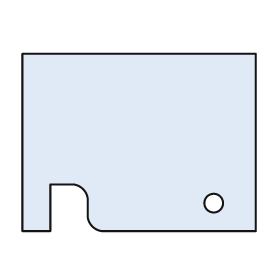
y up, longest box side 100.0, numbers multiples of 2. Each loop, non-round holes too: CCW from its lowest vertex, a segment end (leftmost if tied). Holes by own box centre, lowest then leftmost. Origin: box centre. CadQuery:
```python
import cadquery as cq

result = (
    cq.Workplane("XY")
    .moveTo(-50.0, -38.0)
    .lineTo(-38.0, -38.0)
    .lineTo(-38.0, -18.0)
    .lineTo(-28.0, -18.0)
    .threePointArc((-24.0, -20.0), (-22.0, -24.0))
    .lineTo(-22.0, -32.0)
    .threePointArc((-20.0, -36.0), (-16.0, -38.0))
    .lineTo(50.0, -38.0)
    .lineTo(50.0, 38.0)
    .lineTo(-50.0, 38.0)
    .close()
    .moveTo(32.0, -26.0)
    .circle(4.0)
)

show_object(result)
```